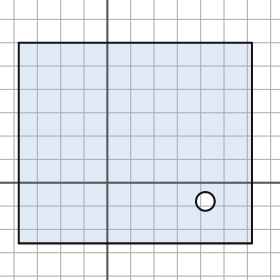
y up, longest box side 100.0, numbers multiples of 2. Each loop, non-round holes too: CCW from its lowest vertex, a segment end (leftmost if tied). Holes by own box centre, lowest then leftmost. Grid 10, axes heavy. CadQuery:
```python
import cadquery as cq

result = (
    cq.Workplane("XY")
    .moveTo(-38.0, -26.0)
    .lineTo(62.0, -26.0)
    .lineTo(62.0, 60.0)
    .lineTo(-38.0, 60.0)
    .close()
    .moveTo(42.0, -8.0)
    .circle(4.0)
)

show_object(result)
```